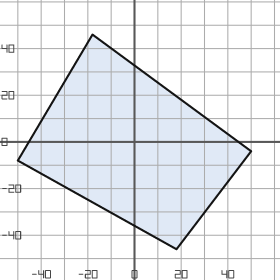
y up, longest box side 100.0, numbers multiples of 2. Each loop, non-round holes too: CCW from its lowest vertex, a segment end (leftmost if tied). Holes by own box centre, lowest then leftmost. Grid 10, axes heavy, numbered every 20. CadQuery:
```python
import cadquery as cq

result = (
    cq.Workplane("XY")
    .moveTo(18.0, -46.0)
    .lineTo(50.0, -4.0)
    .lineTo(-18.0, 46.0)
    .lineTo(-50.0, -8.0)
    .close()
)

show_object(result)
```